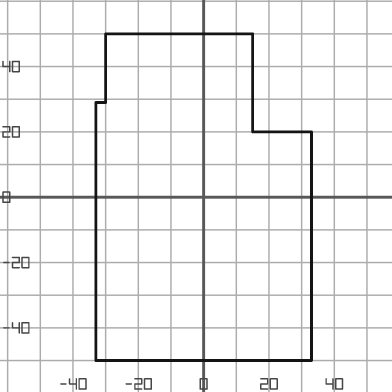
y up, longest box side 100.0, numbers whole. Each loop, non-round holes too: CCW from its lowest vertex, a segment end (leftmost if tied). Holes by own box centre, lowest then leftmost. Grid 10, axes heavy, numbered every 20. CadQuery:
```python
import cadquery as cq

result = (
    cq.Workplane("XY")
    .moveTo(-33.0, -50.0)
    .lineTo(33.0, -50.0)
    .lineTo(33.0, 20.0)
    .lineTo(15.0, 20.0)
    .lineTo(15.0, 50.0)
    .lineTo(-30.0, 50.0)
    .lineTo(-30.0, 29.0)
    .lineTo(-33.0, 29.0)
    .close()
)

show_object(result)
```